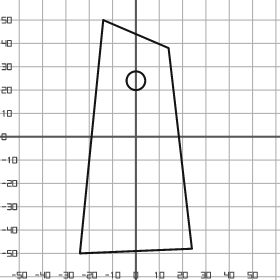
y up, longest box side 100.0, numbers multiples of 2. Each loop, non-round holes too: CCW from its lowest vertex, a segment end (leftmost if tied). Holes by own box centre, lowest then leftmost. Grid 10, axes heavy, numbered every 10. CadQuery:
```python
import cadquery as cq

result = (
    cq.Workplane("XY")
    .moveTo(-24.0, -50.0)
    .lineTo(24.0, -48.0)
    .lineTo(14.0, 38.0)
    .lineTo(-14.0, 50.0)
    .close()
    .moveTo(0.0, 24.0)
    .circle(4.0)
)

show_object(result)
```